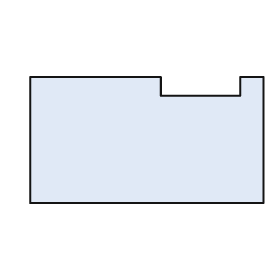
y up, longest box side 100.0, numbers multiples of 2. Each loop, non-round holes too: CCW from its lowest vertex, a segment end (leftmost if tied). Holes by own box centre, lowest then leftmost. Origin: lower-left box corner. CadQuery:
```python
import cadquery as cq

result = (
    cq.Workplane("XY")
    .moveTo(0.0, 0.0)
    .lineTo(100.0, 0.0)
    .lineTo(100.0, 54.0)
    .lineTo(90.0, 54.0)
    .lineTo(90.0, 46.0)
    .lineTo(56.0, 46.0)
    .lineTo(56.0, 54.0)
    .lineTo(0.0, 54.0)
    .close()
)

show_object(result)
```